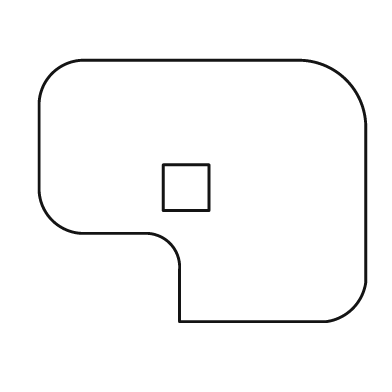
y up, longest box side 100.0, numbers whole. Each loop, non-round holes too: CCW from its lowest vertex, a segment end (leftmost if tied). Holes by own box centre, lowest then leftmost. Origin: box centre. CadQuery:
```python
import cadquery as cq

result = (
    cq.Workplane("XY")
    .moveTo(-7.0, -40.0)
    .lineTo(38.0, -40.0)
    .threePointArc((46.0, -36.0), (50.0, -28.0))
    .lineTo(50.0, 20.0)
    .threePointArc((44.0, 34.0), (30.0, 40.0))
    .lineTo(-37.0, 40.0)
    .threePointArc((-46.0, 36.0), (-50.0, 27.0))
    .lineTo(-50.0, 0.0)
    .threePointArc((-46.0, -9.0), (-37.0, -13.0))
    .lineTo(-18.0, -13.0)
    .threePointArc((-10.0, -16.0), (-7.0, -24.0))
    .close()
    .moveTo(-12.0, -6.0)
    .lineTo(2.0, -6.0)
    .lineTo(2.0, 8.0)
    .lineTo(-12.0, 8.0)
    .close()
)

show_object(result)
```